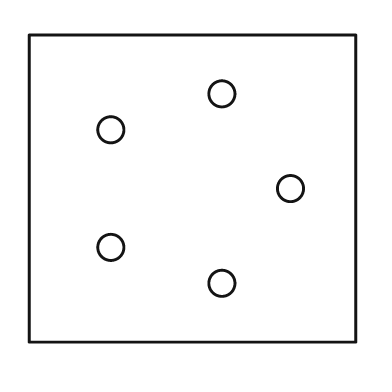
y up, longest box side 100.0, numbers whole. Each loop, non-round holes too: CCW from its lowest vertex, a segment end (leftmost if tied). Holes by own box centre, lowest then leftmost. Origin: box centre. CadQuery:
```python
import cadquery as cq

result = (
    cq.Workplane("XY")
    .moveTo(-50.0, -47.0)
    .lineTo(50.0, -47.0)
    .lineTo(50.0, 47.0)
    .lineTo(-50.0, 47.0)
    .close()
    .moveTo(9.0, -29.0)
    .circle(4.0)
    .moveTo(-25.0, -18.0)
    .circle(4.0)
    .moveTo(30.0, 0.0)
    .circle(4.0)
    .moveTo(-25.0, 18.0)
    .circle(4.0)
    .moveTo(9.0, 29.0)
    .circle(4.0)
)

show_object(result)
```